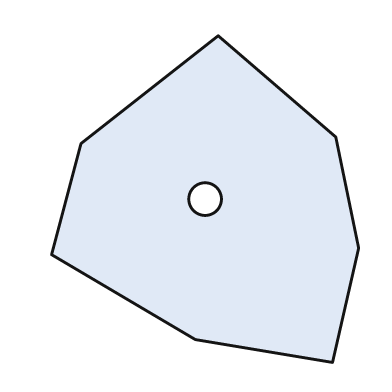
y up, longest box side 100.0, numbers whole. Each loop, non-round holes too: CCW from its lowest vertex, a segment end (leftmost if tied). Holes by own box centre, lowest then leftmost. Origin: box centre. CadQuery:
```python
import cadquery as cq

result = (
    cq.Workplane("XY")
    .moveTo(39.0, -50.0)
    .lineTo(47.0, -15.0)
    .lineTo(40.0, 19.0)
    .lineTo(4.0, 50.0)
    .lineTo(-38.0, 17.0)
    .lineTo(-47.0, -17.0)
    .lineTo(-3.0, -43.0)
    .close()
    .moveTo(0.0, 0.0)
    .circle(5.0)
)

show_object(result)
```